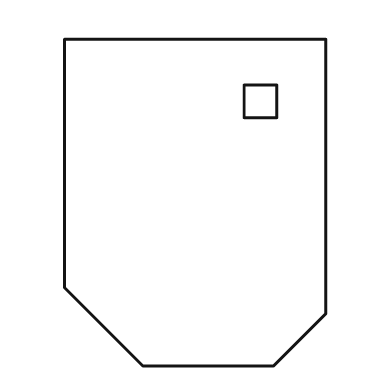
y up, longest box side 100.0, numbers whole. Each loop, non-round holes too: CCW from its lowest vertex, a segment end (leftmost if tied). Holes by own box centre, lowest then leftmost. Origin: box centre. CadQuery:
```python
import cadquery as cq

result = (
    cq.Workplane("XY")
    .moveTo(-16.0, -50.0)
    .lineTo(24.0, -50.0)
    .lineTo(40.0, -34.0)
    .lineTo(40.0, 50.0)
    .lineTo(-40.0, 50.0)
    .lineTo(-40.0, -26.0)
    .close()
    .moveTo(15.0, 26.0)
    .lineTo(25.0, 26.0)
    .lineTo(25.0, 36.0)
    .lineTo(15.0, 36.0)
    .close()
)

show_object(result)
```